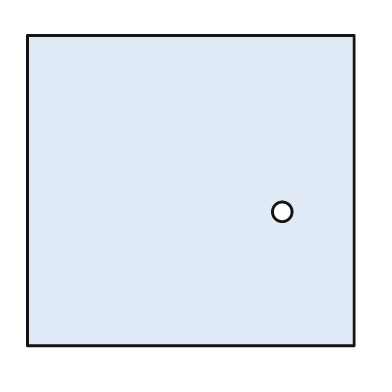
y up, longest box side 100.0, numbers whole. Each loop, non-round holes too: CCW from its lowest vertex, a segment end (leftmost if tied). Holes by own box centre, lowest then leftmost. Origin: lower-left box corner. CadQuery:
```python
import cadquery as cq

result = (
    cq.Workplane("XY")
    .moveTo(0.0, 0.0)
    .lineTo(100.0, 0.0)
    .lineTo(100.0, 95.0)
    .lineTo(0.0, 95.0)
    .close()
    .moveTo(78.0, 41.0)
    .circle(3.0)
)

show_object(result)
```